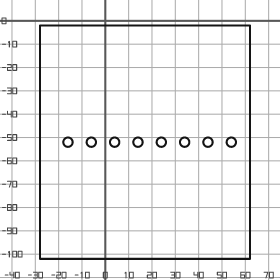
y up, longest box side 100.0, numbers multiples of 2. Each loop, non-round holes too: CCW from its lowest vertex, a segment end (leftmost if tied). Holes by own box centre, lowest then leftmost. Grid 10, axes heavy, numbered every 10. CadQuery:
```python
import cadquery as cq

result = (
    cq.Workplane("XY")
    .moveTo(-28.0, -102.0)
    .lineTo(62.0, -102.0)
    .lineTo(62.0, -2.0)
    .lineTo(-28.0, -2.0)
    .close()
    .moveTo(-16.0, -52.0)
    .circle(2.0)
    .moveTo(-6.0, -52.0)
    .circle(2.0)
    .moveTo(4.0, -52.0)
    .circle(2.0)
    .moveTo(14.0, -52.0)
    .circle(2.0)
    .moveTo(24.0, -52.0)
    .circle(2.0)
    .moveTo(34.0, -52.0)
    .circle(2.0)
    .moveTo(44.0, -52.0)
    .circle(2.0)
    .moveTo(54.0, -52.0)
    .circle(2.0)
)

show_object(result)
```